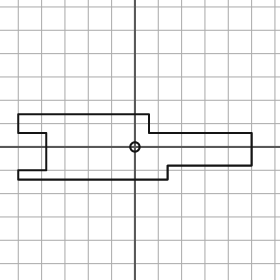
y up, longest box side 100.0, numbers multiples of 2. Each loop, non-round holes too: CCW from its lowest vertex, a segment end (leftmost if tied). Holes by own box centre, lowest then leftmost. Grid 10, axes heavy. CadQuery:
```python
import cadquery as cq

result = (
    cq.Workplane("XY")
    .moveTo(-50.0, -14.0)
    .lineTo(14.0, -14.0)
    .lineTo(14.0, -8.0)
    .lineTo(50.0, -8.0)
    .lineTo(50.0, 6.0)
    .lineTo(6.0, 6.0)
    .lineTo(6.0, 14.0)
    .lineTo(-50.0, 14.0)
    .lineTo(-50.0, 6.0)
    .lineTo(-38.0, 6.0)
    .lineTo(-38.0, -10.0)
    .lineTo(-50.0, -10.0)
    .close()
    .moveTo(0.0, 0.0)
    .circle(2.0)
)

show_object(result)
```